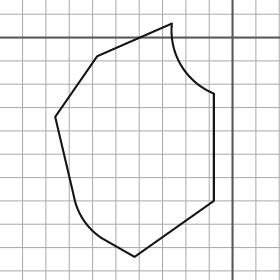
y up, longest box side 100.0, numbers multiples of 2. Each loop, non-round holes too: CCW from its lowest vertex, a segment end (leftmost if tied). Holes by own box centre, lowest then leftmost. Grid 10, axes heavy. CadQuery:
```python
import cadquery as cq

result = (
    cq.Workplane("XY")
    .moveTo(-42.0, -94.0)
    .lineTo(-8.0, -70.0)
    .lineTo(-8.0, -24.0)
    .threePointArc((-22.0, -12.0), (-26.0, 6.0))
    .lineTo(-58.0, -8.0)
    .lineTo(-76.0, -34.0)
    .lineTo(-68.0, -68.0)
    .threePointArc((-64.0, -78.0), (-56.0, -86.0))
    .close()
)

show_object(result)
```